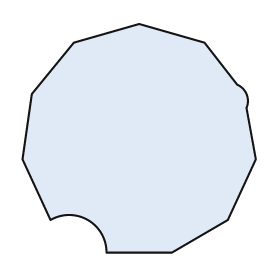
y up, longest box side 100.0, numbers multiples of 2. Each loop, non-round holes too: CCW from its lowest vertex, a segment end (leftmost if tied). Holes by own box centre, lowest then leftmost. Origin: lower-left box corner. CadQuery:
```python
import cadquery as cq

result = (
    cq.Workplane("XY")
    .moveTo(36.0, 0.0)
    .lineTo(64.0, 0.0)
    .lineTo(88.0, 14.0)
    .lineTo(100.0, 40.0)
    .lineTo(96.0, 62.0)
    .threePointArc((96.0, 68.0), (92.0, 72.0))
    .lineTo(78.0, 90.0)
    .lineTo(50.0, 98.0)
    .lineTo(22.0, 90.0)
    .lineTo(4.0, 68.0)
    .lineTo(0.0, 40.0)
    .lineTo(12.0, 14.0)
    .threePointArc((28.0, 14.0), (36.0, 0.0))
    .close()
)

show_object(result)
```